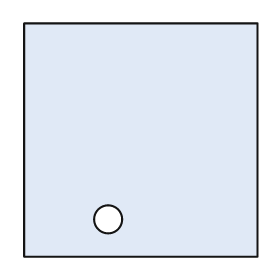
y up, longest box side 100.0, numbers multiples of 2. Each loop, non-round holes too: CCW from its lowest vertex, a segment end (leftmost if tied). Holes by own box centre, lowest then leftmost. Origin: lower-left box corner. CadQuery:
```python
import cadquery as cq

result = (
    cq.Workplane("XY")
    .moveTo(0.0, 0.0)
    .lineTo(100.0, 0.0)
    .lineTo(100.0, 100.0)
    .lineTo(0.0, 100.0)
    .close()
    .moveTo(36.0, 16.0)
    .circle(6.0)
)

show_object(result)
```